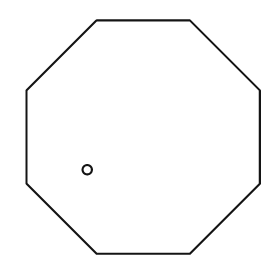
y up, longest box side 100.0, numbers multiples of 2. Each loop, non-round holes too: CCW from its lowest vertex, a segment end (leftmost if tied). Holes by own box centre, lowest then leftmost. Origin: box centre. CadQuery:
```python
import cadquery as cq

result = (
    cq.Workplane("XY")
    .moveTo(-20.0, -50.0)
    .lineTo(20.0, -50.0)
    .lineTo(50.0, -20.0)
    .lineTo(50.0, 20.0)
    .lineTo(20.0, 50.0)
    .lineTo(-20.0, 50.0)
    .lineTo(-50.0, 20.0)
    .lineTo(-50.0, -20.0)
    .close()
    .moveTo(-24.0, -14.0)
    .circle(2.0)
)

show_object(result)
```